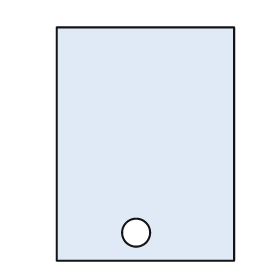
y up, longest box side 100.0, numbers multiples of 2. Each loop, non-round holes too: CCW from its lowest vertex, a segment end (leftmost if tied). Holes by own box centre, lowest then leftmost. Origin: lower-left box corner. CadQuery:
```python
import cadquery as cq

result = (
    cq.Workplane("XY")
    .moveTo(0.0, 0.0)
    .lineTo(76.0, 0.0)
    .lineTo(76.0, 100.0)
    .lineTo(0.0, 100.0)
    .close()
    .moveTo(34.0, 12.0)
    .circle(6.0)
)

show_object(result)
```